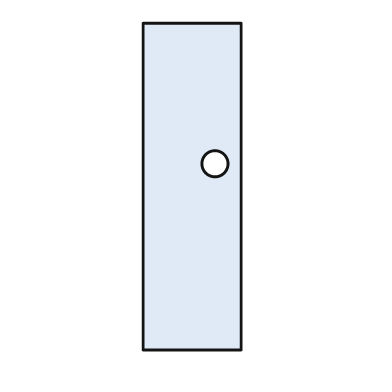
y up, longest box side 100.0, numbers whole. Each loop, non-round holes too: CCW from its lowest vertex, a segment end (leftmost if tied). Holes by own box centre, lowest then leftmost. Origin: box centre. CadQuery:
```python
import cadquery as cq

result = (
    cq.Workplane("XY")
    .moveTo(-15.0, -50.0)
    .lineTo(15.0, -50.0)
    .lineTo(15.0, 50.0)
    .lineTo(-15.0, 50.0)
    .close()
    .moveTo(7.0, 7.0)
    .circle(4.0)
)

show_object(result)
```